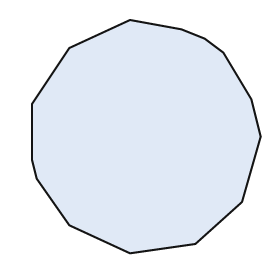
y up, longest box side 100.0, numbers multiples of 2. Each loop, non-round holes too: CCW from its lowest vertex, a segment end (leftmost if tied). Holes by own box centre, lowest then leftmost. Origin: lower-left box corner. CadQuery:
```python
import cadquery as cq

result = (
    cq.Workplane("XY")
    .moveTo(42.0, 0.0)
    .lineTo(70.0, 4.0)
    .lineTo(90.0, 22.0)
    .lineTo(98.0, 50.0)
    .lineTo(94.0, 66.0)
    .lineTo(82.0, 86.0)
    .lineTo(74.0, 92.0)
    .lineTo(64.0, 96.0)
    .lineTo(42.0, 100.0)
    .lineTo(16.0, 88.0)
    .lineTo(0.0, 64.0)
    .lineTo(0.0, 40.0)
    .lineTo(2.0, 32.0)
    .lineTo(16.0, 12.0)
    .close()
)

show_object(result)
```